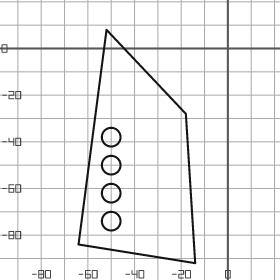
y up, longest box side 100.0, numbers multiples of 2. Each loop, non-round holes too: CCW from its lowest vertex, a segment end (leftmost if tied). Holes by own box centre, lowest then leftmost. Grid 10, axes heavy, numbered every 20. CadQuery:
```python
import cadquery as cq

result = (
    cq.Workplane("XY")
    .moveTo(-14.0, -92.0)
    .lineTo(-18.0, -28.0)
    .lineTo(-52.0, 8.0)
    .lineTo(-64.0, -84.0)
    .close()
    .moveTo(-50.0, -74.0)
    .circle(4.0)
    .moveTo(-50.0, -62.0)
    .circle(4.0)
    .moveTo(-50.0, -50.0)
    .circle(4.0)
    .moveTo(-50.0, -38.0)
    .circle(4.0)
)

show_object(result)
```